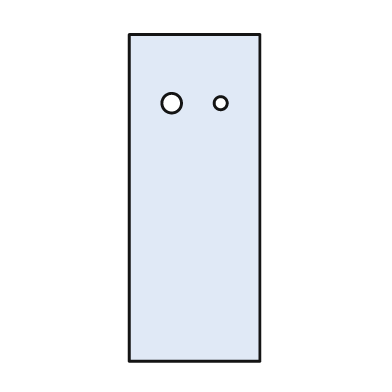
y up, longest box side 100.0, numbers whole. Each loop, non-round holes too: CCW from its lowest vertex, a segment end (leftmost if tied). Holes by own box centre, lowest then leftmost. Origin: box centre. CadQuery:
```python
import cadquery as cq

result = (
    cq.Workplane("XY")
    .moveTo(-20.0, -50.0)
    .lineTo(20.0, -50.0)
    .lineTo(20.0, 50.0)
    .lineTo(-20.0, 50.0)
    .close()
    .moveTo(-7.0, 29.0)
    .circle(3.0)
    .moveTo(8.0, 29.0)
    .circle(2.0)
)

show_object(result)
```